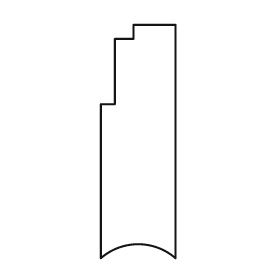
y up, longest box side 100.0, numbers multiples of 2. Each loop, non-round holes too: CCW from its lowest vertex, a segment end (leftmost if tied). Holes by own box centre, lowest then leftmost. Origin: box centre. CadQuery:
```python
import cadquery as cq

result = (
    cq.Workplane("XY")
    .moveTo(-16.0, -50.0)
    .threePointArc((0.0, -44.0), (16.0, -50.0))
    .lineTo(16.0, 50.0)
    .lineTo(-2.0, 50.0)
    .lineTo(-2.0, 44.0)
    .lineTo(-10.0, 44.0)
    .lineTo(-10.0, 16.0)
    .lineTo(-16.0, 16.0)
    .close()
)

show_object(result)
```